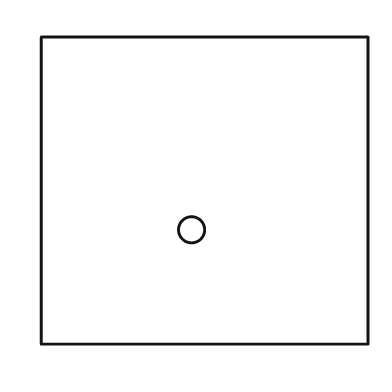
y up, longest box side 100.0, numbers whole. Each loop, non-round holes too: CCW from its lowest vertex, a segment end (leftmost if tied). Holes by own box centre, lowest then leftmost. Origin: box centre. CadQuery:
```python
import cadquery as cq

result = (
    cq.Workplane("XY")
    .moveTo(-50.0, -47.0)
    .lineTo(50.0, -47.0)
    .lineTo(50.0, 47.0)
    .lineTo(-50.0, 47.0)
    .close()
    .moveTo(-4.0, -12.0)
    .circle(4.0)
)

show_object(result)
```